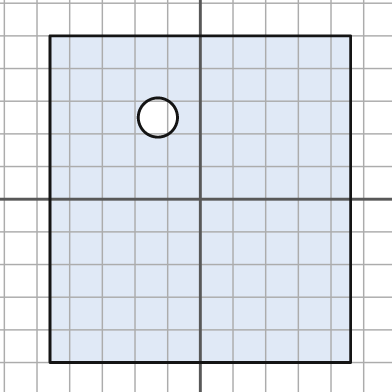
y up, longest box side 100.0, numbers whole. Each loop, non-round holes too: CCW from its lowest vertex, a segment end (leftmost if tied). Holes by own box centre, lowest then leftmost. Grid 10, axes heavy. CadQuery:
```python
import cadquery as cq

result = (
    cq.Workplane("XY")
    .moveTo(-46.0, -50.0)
    .lineTo(46.0, -50.0)
    .lineTo(46.0, 50.0)
    .lineTo(-46.0, 50.0)
    .close()
    .moveTo(-13.0, 25.0)
    .circle(6.0)
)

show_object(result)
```